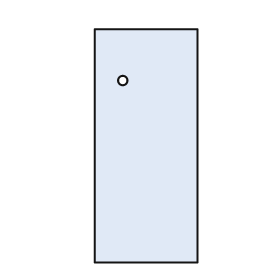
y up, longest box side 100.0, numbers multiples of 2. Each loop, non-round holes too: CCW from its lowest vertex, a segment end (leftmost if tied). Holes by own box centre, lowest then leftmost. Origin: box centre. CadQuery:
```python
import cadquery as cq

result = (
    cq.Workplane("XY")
    .moveTo(-22.0, -50.0)
    .lineTo(22.0, -50.0)
    .lineTo(22.0, 50.0)
    .lineTo(-22.0, 50.0)
    .close()
    .moveTo(-10.0, 28.0)
    .circle(2.0)
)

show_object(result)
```